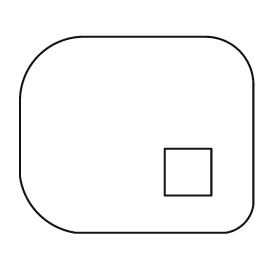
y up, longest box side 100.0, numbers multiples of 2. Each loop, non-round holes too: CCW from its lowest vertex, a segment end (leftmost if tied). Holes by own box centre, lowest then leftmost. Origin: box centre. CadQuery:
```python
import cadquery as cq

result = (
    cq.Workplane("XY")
    .moveTo(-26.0, -42.0)
    .lineTo(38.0, -42.0)
    .threePointArc((46.0, -38.0), (50.0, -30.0))
    .lineTo(50.0, 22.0)
    .threePointArc((44.0, 36.0), (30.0, 42.0))
    .lineTo(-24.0, 42.0)
    .threePointArc((-42.0, 34.0), (-50.0, 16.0))
    .lineTo(-50.0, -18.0)
    .threePointArc((-42.0, -34.0), (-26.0, -42.0))
    .close()
    .moveTo(12.0, -26.0)
    .lineTo(32.0, -26.0)
    .lineTo(32.0, -6.0)
    .lineTo(12.0, -6.0)
    .close()
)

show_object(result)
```